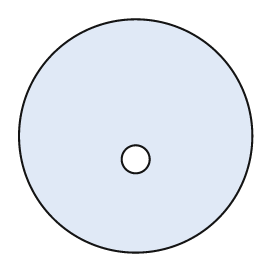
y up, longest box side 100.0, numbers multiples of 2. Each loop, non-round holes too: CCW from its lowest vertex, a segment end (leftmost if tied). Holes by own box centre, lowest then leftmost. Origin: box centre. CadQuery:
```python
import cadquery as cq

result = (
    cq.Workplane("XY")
    .moveTo(0.0, 0.0)
    .circle(50.0)
    .moveTo(0.0, -10.0)
    .circle(6.0)
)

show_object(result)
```